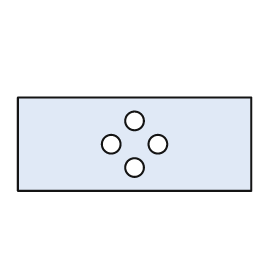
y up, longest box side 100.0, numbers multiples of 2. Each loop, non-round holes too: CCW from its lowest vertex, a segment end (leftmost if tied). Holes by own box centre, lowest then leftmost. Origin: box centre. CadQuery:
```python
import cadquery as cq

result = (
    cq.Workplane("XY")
    .moveTo(-50.0, -20.0)
    .lineTo(50.0, -20.0)
    .lineTo(50.0, 20.0)
    .lineTo(-50.0, 20.0)
    .close()
    .moveTo(0.0, -10.0)
    .circle(4.0)
    .moveTo(-10.0, 0.0)
    .circle(4.0)
    .moveTo(10.0, 0.0)
    .circle(4.0)
    .moveTo(0.0, 10.0)
    .circle(4.0)
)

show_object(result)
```